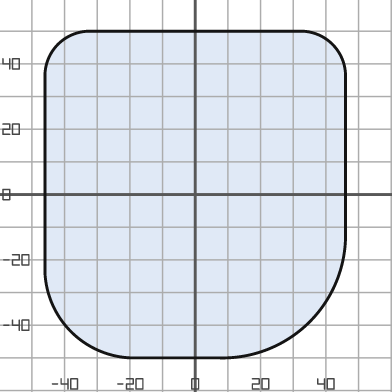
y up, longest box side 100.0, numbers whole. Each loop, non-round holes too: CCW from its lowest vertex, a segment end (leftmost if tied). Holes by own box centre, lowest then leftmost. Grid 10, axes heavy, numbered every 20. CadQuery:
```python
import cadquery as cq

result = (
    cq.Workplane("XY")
    .moveTo(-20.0, -50.0)
    .lineTo(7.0, -50.0)
    .threePointArc((35.0, -39.0), (46.0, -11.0))
    .lineTo(46.0, 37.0)
    .threePointArc((42.0, 46.0), (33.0, 50.0))
    .lineTo(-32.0, 50.0)
    .threePointArc((-42.0, 46.0), (-46.0, 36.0))
    .lineTo(-46.0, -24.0)
    .threePointArc((-38.0, -42.0), (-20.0, -50.0))
    .close()
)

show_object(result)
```